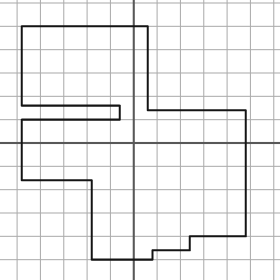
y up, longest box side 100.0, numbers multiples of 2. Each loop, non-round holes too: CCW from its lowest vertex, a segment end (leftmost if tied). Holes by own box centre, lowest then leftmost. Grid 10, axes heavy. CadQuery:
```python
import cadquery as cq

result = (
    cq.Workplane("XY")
    .moveTo(-18.0, -50.0)
    .lineTo(8.0, -50.0)
    .lineTo(8.0, -46.0)
    .lineTo(24.0, -46.0)
    .lineTo(24.0, -40.0)
    .lineTo(48.0, -40.0)
    .lineTo(48.0, 14.0)
    .lineTo(6.0, 14.0)
    .lineTo(6.0, 50.0)
    .lineTo(-48.0, 50.0)
    .lineTo(-48.0, 16.0)
    .lineTo(-6.0, 16.0)
    .lineTo(-6.0, 10.0)
    .lineTo(-48.0, 10.0)
    .lineTo(-48.0, -16.0)
    .lineTo(-18.0, -16.0)
    .close()
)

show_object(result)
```